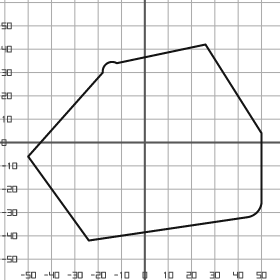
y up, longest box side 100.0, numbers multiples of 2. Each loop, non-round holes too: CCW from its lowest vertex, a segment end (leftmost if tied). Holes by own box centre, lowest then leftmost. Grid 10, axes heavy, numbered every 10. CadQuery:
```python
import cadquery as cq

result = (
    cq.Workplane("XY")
    .moveTo(-24.0, -42.0)
    .lineTo(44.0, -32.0)
    .threePointArc((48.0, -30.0), (50.0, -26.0))
    .lineTo(50.0, 4.0)
    .lineTo(26.0, 42.0)
    .lineTo(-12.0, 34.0)
    .threePointArc((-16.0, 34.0), (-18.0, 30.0))
    .lineTo(-50.0, -6.0)
    .close()
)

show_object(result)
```